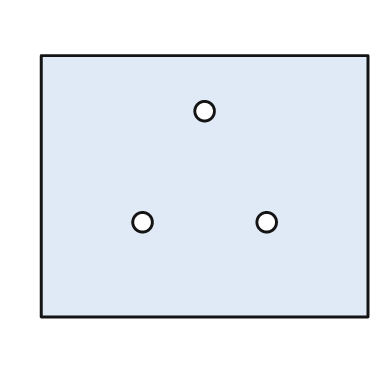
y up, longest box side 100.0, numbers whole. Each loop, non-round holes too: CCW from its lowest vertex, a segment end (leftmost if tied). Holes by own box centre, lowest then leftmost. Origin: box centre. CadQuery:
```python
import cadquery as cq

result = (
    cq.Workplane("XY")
    .moveTo(-50.0, -40.0)
    .lineTo(50.0, -40.0)
    .lineTo(50.0, 40.0)
    .lineTo(-50.0, 40.0)
    .close()
    .moveTo(-19.0, -11.0)
    .circle(3.0)
    .moveTo(19.0, -11.0)
    .circle(3.0)
    .moveTo(0.0, 23.0)
    .circle(3.0)
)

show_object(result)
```